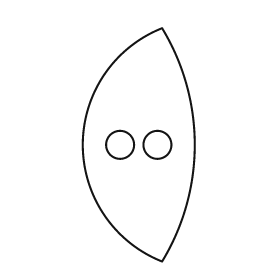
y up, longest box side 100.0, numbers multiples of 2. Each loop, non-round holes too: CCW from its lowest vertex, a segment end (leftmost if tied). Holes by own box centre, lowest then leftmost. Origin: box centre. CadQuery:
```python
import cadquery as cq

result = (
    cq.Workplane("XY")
    .moveTo(10.0, -50.0)
    .threePointArc((24.0, 0.0), (10.0, 50.0))
    .threePointArc((-24.0, 0.0), (10.0, -50.0))
    .close()
    .moveTo(-8.0, 0.0)
    .circle(6.0)
    .moveTo(8.0, 0.0)
    .circle(6.0)
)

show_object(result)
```